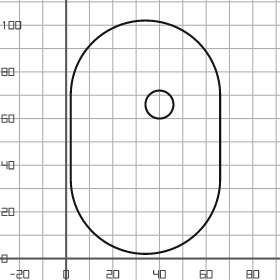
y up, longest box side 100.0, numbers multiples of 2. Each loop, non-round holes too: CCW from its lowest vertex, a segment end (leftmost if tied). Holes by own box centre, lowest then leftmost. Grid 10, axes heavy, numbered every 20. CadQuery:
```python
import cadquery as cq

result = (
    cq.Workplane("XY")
    .moveTo(2.0, 34.0)
    .threePointArc((34.0, 2.0), (66.0, 34.0))
    .lineTo(66.0, 70.0)
    .threePointArc((34.0, 102.0), (2.0, 70.0))
    .close()
    .moveTo(40.0, 66.0)
    .circle(6.0)
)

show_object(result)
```